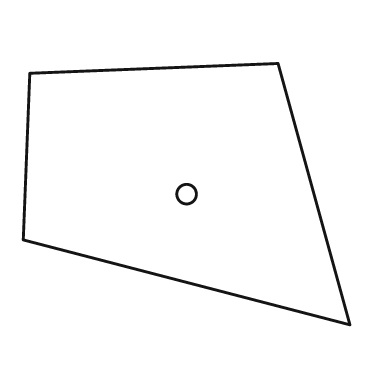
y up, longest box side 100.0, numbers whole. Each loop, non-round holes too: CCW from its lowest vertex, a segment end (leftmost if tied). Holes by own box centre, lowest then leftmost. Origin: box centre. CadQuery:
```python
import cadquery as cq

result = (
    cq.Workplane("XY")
    .moveTo(50.0, -40.0)
    .lineTo(28.0, 40.0)
    .lineTo(-48.0, 37.0)
    .lineTo(-50.0, -14.0)
    .close()
    .moveTo(0.0, 0.0)
    .circle(3.0)
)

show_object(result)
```